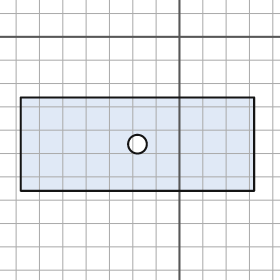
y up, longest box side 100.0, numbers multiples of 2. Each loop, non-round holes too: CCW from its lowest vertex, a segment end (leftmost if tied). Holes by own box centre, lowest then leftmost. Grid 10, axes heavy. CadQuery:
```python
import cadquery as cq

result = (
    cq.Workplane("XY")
    .moveTo(-68.0, -66.0)
    .lineTo(32.0, -66.0)
    .lineTo(32.0, -26.0)
    .lineTo(-68.0, -26.0)
    .close()
    .moveTo(-18.0, -46.0)
    .circle(4.0)
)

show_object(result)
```